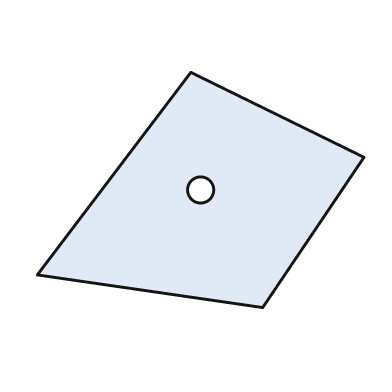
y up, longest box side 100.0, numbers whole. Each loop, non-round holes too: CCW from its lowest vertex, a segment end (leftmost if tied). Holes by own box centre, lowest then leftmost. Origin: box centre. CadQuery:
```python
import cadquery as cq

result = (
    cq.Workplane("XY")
    .moveTo(19.0, -36.0)
    .lineTo(50.0, 10.0)
    .lineTo(-3.0, 36.0)
    .lineTo(-50.0, -26.0)
    .close()
    .moveTo(0.0, 0.0)
    .circle(4.0)
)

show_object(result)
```